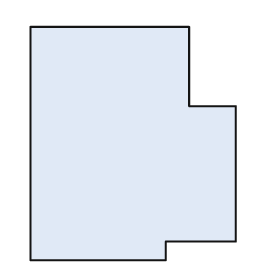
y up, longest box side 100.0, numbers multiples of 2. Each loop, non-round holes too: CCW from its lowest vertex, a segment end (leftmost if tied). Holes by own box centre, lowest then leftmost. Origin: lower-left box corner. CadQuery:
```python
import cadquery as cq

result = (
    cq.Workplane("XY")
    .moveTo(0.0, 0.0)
    .lineTo(58.0, 0.0)
    .lineTo(58.0, 8.0)
    .lineTo(88.0, 8.0)
    .lineTo(88.0, 66.0)
    .lineTo(68.0, 66.0)
    .lineTo(68.0, 100.0)
    .lineTo(0.0, 100.0)
    .close()
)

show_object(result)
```